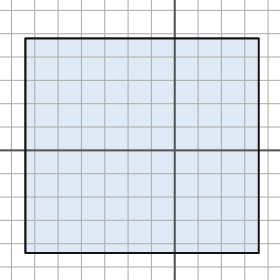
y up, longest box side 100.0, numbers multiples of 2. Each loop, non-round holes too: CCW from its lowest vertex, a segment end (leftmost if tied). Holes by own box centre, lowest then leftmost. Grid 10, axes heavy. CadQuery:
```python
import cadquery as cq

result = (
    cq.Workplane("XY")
    .moveTo(-64.0, -44.0)
    .lineTo(36.0, -44.0)
    .lineTo(36.0, 48.0)
    .lineTo(-64.0, 48.0)
    .close()
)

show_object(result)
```